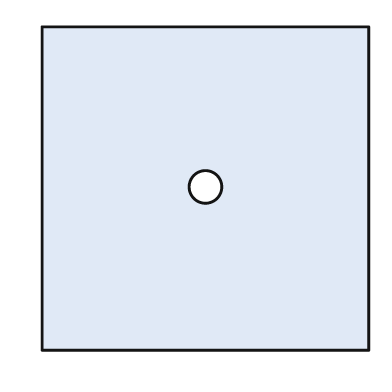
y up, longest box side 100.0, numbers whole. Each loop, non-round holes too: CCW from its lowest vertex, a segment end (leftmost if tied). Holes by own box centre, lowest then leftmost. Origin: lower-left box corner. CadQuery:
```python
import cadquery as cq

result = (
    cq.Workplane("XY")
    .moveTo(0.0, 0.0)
    .lineTo(100.0, 0.0)
    .lineTo(100.0, 99.0)
    .lineTo(0.0, 99.0)
    .close()
    .moveTo(50.0, 50.0)
    .circle(5.0)
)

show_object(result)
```